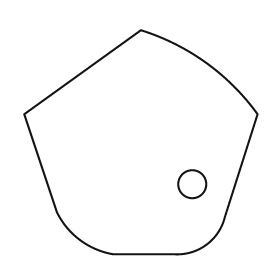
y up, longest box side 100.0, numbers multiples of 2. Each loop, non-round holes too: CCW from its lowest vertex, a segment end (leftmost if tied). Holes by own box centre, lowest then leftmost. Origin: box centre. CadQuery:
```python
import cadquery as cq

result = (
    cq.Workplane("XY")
    .moveTo(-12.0, -48.0)
    .lineTo(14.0, -48.0)
    .threePointArc((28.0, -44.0), (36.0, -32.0))
    .lineTo(50.0, 12.0)
    .threePointArc((28.0, 34.0), (0.0, 48.0))
    .lineTo(-50.0, 12.0)
    .lineTo(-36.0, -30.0)
    .threePointArc((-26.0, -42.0), (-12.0, -48.0))
    .close()
    .moveTo(22.0, -18.0)
    .circle(6.0)
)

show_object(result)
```